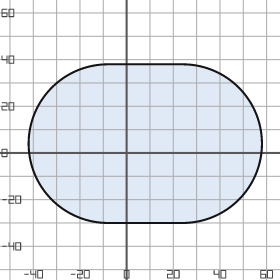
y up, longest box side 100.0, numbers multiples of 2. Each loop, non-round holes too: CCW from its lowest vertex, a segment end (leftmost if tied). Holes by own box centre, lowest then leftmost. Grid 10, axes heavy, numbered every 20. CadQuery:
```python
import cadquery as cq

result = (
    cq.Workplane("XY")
    .moveTo(-8.0, -30.0)
    .lineTo(24.0, -30.0)
    .threePointArc((58.0, 4.0), (24.0, 38.0))
    .lineTo(-8.0, 38.0)
    .threePointArc((-42.0, 4.0), (-8.0, -30.0))
    .close()
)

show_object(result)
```